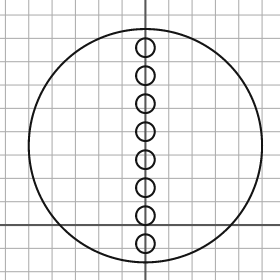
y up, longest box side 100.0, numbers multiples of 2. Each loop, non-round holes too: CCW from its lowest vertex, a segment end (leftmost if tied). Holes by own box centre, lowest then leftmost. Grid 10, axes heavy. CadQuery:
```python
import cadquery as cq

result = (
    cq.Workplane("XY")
    .moveTo(0.0, 34.0)
    .circle(50.0)
    .moveTo(0.0, -8.0)
    .circle(4.0)
    .moveTo(0.0, 4.0)
    .circle(4.0)
    .moveTo(0.0, 16.0)
    .circle(4.0)
    .moveTo(0.0, 28.0)
    .circle(4.0)
    .moveTo(0.0, 40.0)
    .circle(4.0)
    .moveTo(0.0, 52.0)
    .circle(4.0)
    .moveTo(0.0, 64.0)
    .circle(4.0)
    .moveTo(0.0, 76.0)
    .circle(4.0)
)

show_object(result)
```